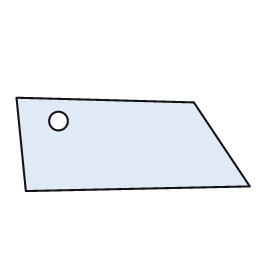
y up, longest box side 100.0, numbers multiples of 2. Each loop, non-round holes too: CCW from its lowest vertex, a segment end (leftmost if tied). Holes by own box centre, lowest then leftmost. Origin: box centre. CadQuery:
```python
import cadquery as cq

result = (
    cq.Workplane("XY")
    .moveTo(-46.0, -20.0)
    .lineTo(50.0, -18.0)
    .lineTo(26.0, 18.0)
    .lineTo(-50.0, 20.0)
    .close()
    .moveTo(-32.0, 10.0)
    .circle(4.0)
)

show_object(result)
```